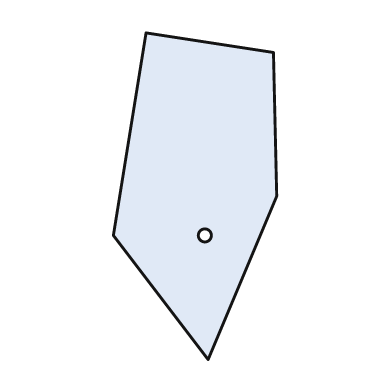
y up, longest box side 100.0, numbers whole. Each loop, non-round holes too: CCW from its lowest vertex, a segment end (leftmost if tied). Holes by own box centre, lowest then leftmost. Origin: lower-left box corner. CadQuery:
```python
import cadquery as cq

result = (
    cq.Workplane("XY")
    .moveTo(29.0, 0.0)
    .lineTo(50.0, 50.0)
    .lineTo(49.0, 94.0)
    .lineTo(10.0, 100.0)
    .lineTo(0.0, 38.0)
    .close()
    .moveTo(28.0, 38.0)
    .circle(2.0)
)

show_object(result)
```